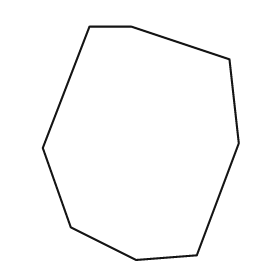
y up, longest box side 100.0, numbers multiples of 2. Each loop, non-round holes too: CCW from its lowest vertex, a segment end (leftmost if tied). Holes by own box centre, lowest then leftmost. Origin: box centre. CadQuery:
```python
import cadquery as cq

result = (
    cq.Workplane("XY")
    .moveTo(-2.0, -50.0)
    .lineTo(24.0, -48.0)
    .lineTo(42.0, 0.0)
    .lineTo(38.0, 36.0)
    .lineTo(-4.0, 50.0)
    .lineTo(-22.0, 50.0)
    .lineTo(-42.0, -2.0)
    .lineTo(-30.0, -36.0)
    .close()
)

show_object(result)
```